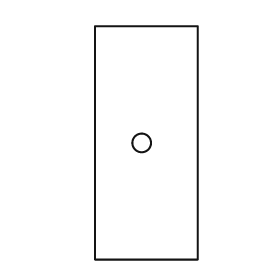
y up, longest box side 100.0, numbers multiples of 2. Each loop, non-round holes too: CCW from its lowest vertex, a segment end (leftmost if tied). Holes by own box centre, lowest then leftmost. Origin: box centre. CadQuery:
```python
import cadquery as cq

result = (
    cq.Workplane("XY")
    .moveTo(-22.0, -50.0)
    .lineTo(22.0, -50.0)
    .lineTo(22.0, 50.0)
    .lineTo(-22.0, 50.0)
    .close()
    .moveTo(-2.0, 0.0)
    .circle(4.0)
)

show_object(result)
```